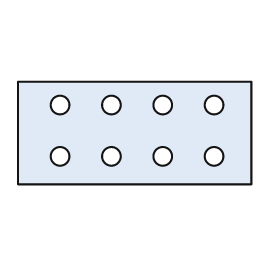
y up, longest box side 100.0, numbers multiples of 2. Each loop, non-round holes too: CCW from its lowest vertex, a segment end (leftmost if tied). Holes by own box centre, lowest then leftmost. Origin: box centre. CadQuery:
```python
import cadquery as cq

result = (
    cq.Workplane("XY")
    .moveTo(-50.0, -22.0)
    .lineTo(50.0, -22.0)
    .lineTo(50.0, 22.0)
    .lineTo(-50.0, 22.0)
    .close()
    .moveTo(-32.0, -10.0)
    .circle(4.0)
    .moveTo(-10.0, -10.0)
    .circle(4.0)
    .moveTo(12.0, -10.0)
    .circle(4.0)
    .moveTo(34.0, -10.0)
    .circle(4.0)
    .moveTo(-32.0, 12.0)
    .circle(4.0)
    .moveTo(-10.0, 12.0)
    .circle(4.0)
    .moveTo(12.0, 12.0)
    .circle(4.0)
    .moveTo(34.0, 12.0)
    .circle(4.0)
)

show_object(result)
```